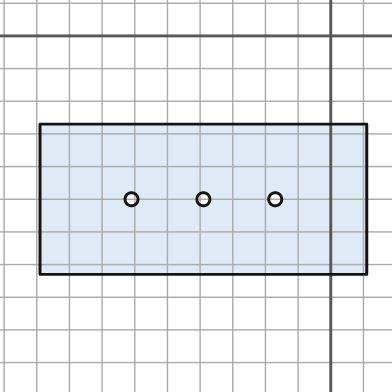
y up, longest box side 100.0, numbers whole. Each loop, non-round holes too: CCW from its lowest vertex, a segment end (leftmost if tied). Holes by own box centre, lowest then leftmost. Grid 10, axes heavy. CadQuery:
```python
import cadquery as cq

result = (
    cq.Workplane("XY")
    .moveTo(-89.0, -73.0)
    .lineTo(11.0, -73.0)
    .lineTo(11.0, -27.0)
    .lineTo(-89.0, -27.0)
    .close()
    .moveTo(-61.0, -50.0)
    .circle(2.0)
    .moveTo(-39.0, -50.0)
    .circle(2.0)
    .moveTo(-17.0, -50.0)
    .circle(2.0)
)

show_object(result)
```